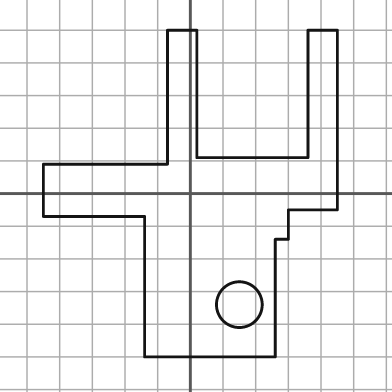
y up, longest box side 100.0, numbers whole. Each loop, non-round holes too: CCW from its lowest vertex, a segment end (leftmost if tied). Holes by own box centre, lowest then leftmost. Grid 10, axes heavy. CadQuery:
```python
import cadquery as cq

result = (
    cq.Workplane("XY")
    .moveTo(-14.0, -50.0)
    .lineTo(26.0, -50.0)
    .lineTo(26.0, -14.0)
    .lineTo(30.0, -14.0)
    .lineTo(30.0, -5.0)
    .lineTo(45.0, -5.0)
    .lineTo(45.0, 50.0)
    .lineTo(36.0, 50.0)
    .lineTo(36.0, 11.0)
    .lineTo(2.0, 11.0)
    .lineTo(2.0, 50.0)
    .lineTo(-7.0, 50.0)
    .lineTo(-7.0, 9.0)
    .lineTo(-45.0, 9.0)
    .lineTo(-45.0, -7.0)
    .lineTo(-14.0, -7.0)
    .close()
    .moveTo(15.0, -34.0)
    .circle(7.0)
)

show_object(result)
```